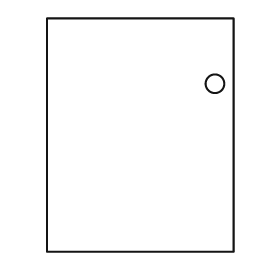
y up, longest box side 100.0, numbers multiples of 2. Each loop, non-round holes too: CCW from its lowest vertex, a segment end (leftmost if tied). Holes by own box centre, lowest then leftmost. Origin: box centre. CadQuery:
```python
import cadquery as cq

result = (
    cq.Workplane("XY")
    .moveTo(-40.0, -50.0)
    .lineTo(40.0, -50.0)
    .lineTo(40.0, 50.0)
    .lineTo(-40.0, 50.0)
    .close()
    .moveTo(32.0, 22.0)
    .circle(4.0)
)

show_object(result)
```